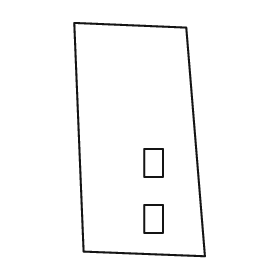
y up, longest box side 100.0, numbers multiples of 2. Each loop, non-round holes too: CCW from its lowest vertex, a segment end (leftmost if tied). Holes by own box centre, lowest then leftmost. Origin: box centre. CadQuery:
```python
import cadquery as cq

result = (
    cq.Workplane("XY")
    .moveTo(28.0, -50.0)
    .lineTo(20.0, 48.0)
    .lineTo(-28.0, 50.0)
    .lineTo(-24.0, -48.0)
    .close()
    .moveTo(2.0, -40.0)
    .lineTo(10.0, -40.0)
    .lineTo(10.0, -28.0)
    .lineTo(2.0, -28.0)
    .close()
    .moveTo(2.0, -16.0)
    .lineTo(10.0, -16.0)
    .lineTo(10.0, -4.0)
    .lineTo(2.0, -4.0)
    .close()
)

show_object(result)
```